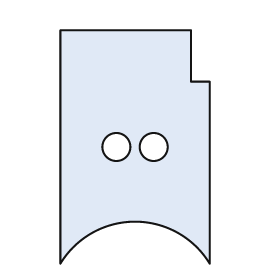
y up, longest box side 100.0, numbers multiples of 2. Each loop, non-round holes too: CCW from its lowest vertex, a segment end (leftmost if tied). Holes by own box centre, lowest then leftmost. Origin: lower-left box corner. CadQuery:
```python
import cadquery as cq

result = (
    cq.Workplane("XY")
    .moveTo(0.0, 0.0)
    .threePointArc((32.0, 18.0), (64.0, 0.0))
    .lineTo(64.0, 78.0)
    .lineTo(56.0, 78.0)
    .lineTo(56.0, 100.0)
    .lineTo(0.0, 100.0)
    .close()
    .moveTo(24.0, 50.0)
    .circle(6.0)
    .moveTo(40.0, 50.0)
    .circle(6.0)
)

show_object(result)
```